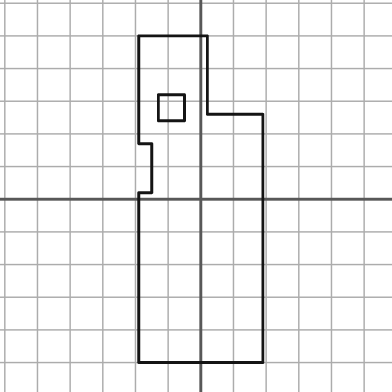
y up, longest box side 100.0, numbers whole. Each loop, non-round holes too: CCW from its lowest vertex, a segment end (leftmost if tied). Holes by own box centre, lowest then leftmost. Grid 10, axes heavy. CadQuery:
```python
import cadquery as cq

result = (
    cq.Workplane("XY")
    .moveTo(-19.0, -50.0)
    .lineTo(19.0, -50.0)
    .lineTo(19.0, 26.0)
    .lineTo(2.0, 26.0)
    .lineTo(2.0, 50.0)
    .lineTo(-19.0, 50.0)
    .lineTo(-19.0, 17.0)
    .lineTo(-15.0, 17.0)
    .lineTo(-15.0, 2.0)
    .lineTo(-19.0, 2.0)
    .close()
    .moveTo(-13.0, 24.0)
    .lineTo(-5.0, 24.0)
    .lineTo(-5.0, 32.0)
    .lineTo(-13.0, 32.0)
    .close()
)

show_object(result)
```